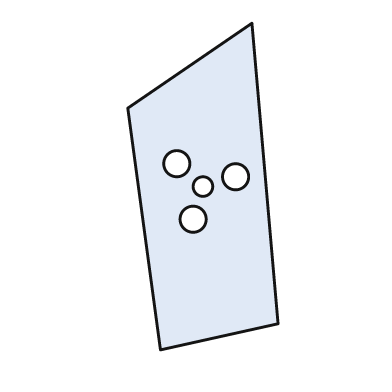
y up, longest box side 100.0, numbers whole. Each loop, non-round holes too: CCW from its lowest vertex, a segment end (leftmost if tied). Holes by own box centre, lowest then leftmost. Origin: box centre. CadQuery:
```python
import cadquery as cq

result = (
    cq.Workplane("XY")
    .moveTo(-13.0, -50.0)
    .lineTo(23.0, -42.0)
    .lineTo(15.0, 50.0)
    .lineTo(-23.0, 24.0)
    .close()
    .moveTo(-3.0, -10.0)
    .circle(4.0)
    .moveTo(0.0, 0.0)
    .circle(3.0)
    .moveTo(10.0, 3.0)
    .circle(4.0)
    .moveTo(-8.0, 7.0)
    .circle(4.0)
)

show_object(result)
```